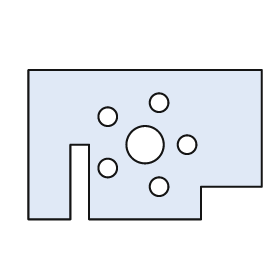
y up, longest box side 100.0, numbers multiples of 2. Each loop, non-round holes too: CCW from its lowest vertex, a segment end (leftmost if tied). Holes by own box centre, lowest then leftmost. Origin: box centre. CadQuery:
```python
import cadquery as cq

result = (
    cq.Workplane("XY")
    .moveTo(-50.0, -32.0)
    .lineTo(-32.0, -32.0)
    .lineTo(-32.0, 0.0)
    .lineTo(-24.0, 0.0)
    .lineTo(-24.0, -32.0)
    .lineTo(24.0, -32.0)
    .lineTo(24.0, -18.0)
    .lineTo(50.0, -18.0)
    .lineTo(50.0, 32.0)
    .lineTo(-50.0, 32.0)
    .close()
    .moveTo(6.0, -18.0)
    .circle(4.0)
    .moveTo(-16.0, -10.0)
    .circle(4.0)
    .moveTo(0.0, 0.0)
    .circle(8.0)
    .moveTo(18.0, 0.0)
    .circle(4.0)
    .moveTo(-16.0, 12.0)
    .circle(4.0)
    .moveTo(6.0, 18.0)
    .circle(4.0)
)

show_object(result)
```